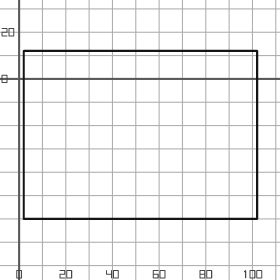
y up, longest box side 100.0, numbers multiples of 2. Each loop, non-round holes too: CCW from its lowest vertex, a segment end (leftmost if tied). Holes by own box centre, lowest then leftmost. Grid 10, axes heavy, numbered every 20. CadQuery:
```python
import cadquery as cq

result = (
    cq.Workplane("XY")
    .moveTo(2.0, -60.0)
    .lineTo(102.0, -60.0)
    .lineTo(102.0, 12.0)
    .lineTo(2.0, 12.0)
    .close()
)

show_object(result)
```